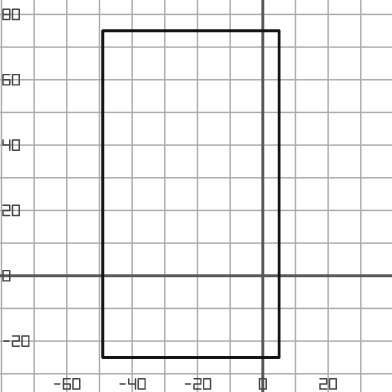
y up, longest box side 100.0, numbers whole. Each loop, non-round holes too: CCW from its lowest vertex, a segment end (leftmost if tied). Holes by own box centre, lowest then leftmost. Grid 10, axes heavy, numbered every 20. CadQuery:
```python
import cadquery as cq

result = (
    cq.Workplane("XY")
    .moveTo(-49.0, -25.0)
    .lineTo(5.0, -25.0)
    .lineTo(5.0, 75.0)
    .lineTo(-49.0, 75.0)
    .close()
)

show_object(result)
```